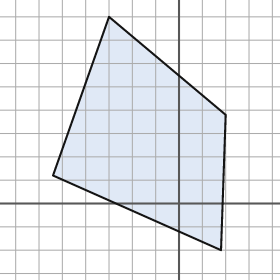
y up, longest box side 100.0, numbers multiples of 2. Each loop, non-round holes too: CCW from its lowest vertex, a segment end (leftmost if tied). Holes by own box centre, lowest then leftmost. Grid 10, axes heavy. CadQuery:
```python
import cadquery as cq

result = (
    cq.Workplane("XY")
    .moveTo(18.0, -20.0)
    .lineTo(20.0, 38.0)
    .lineTo(-30.0, 80.0)
    .lineTo(-54.0, 12.0)
    .close()
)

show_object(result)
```